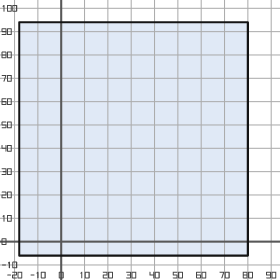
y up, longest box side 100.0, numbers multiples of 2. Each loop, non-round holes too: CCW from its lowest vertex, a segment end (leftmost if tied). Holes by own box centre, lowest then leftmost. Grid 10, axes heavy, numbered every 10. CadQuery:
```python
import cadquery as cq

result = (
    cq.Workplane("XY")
    .moveTo(-18.0, -6.0)
    .lineTo(80.0, -6.0)
    .lineTo(80.0, 94.0)
    .lineTo(-18.0, 94.0)
    .close()
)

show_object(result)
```